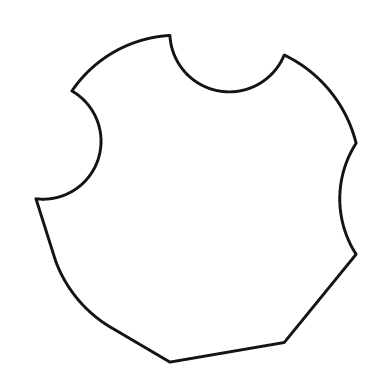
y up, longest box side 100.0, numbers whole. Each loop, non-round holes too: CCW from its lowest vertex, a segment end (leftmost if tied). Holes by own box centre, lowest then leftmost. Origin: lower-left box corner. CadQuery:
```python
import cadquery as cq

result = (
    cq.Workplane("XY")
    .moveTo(41.0, 0.0)
    .lineTo(76.0, 6.0)
    .lineTo(98.0, 33.0)
    .threePointArc((93.0, 50.0), (98.0, 67.0))
    .threePointArc((90.0, 83.0), (76.0, 94.0))
    .threePointArc((56.0, 83.0), (41.0, 100.0))
    .threePointArc((24.0, 95.0), (11.0, 83.0))
    .threePointArc((19.0, 62.0), (0.0, 50.0))
    .lineTo(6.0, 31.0)
    .threePointArc((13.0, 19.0), (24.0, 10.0))
    .close()
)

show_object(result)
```